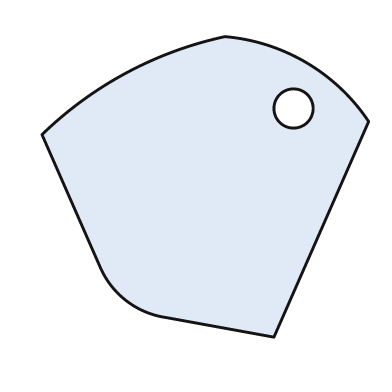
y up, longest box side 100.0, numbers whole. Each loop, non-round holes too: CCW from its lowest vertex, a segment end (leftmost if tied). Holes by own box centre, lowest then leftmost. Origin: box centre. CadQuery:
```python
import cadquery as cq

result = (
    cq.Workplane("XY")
    .moveTo(21.0, -46.0)
    .lineTo(50.0, 20.0)
    .threePointArc((31.0, 38.0), (6.0, 46.0))
    .threePointArc((-24.0, 35.0), (-50.0, 16.0))
    .lineTo(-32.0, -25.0)
    .threePointArc((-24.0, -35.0), (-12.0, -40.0))
    .close()
    .moveTo(27.0, 24.0)
    .circle(6.0)
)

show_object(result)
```